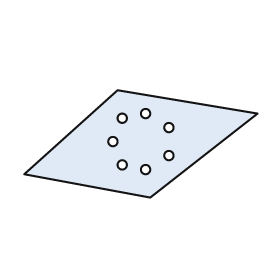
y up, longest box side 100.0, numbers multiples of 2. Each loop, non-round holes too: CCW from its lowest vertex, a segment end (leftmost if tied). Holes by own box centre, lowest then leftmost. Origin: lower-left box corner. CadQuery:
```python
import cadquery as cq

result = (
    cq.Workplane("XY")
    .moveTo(54.0, 0.0)
    .lineTo(100.0, 36.0)
    .lineTo(40.0, 46.0)
    .lineTo(0.0, 10.0)
    .close()
    .moveTo(52.0, 12.0)
    .circle(2.0)
    .moveTo(42.0, 14.0)
    .circle(2.0)
    .moveTo(62.0, 18.0)
    .circle(2.0)
    .moveTo(38.0, 24.0)
    .circle(2.0)
    .moveTo(62.0, 30.0)
    .circle(2.0)
    .moveTo(42.0, 34.0)
    .circle(2.0)
    .moveTo(52.0, 36.0)
    .circle(2.0)
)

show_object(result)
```